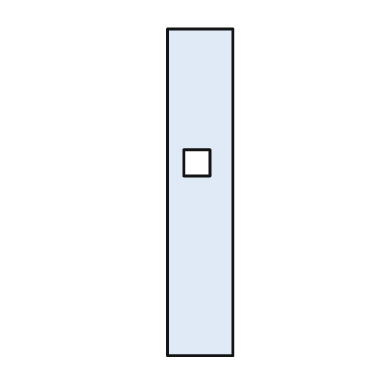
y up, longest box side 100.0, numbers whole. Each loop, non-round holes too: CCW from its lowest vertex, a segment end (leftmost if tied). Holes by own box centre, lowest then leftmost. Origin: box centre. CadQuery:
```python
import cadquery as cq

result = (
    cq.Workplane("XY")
    .moveTo(-10.0, -50.0)
    .lineTo(10.0, -50.0)
    .lineTo(10.0, 50.0)
    .lineTo(-10.0, 50.0)
    .close()
    .moveTo(-5.0, 5.0)
    .lineTo(3.0, 5.0)
    .lineTo(3.0, 13.0)
    .lineTo(-5.0, 13.0)
    .close()
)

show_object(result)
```